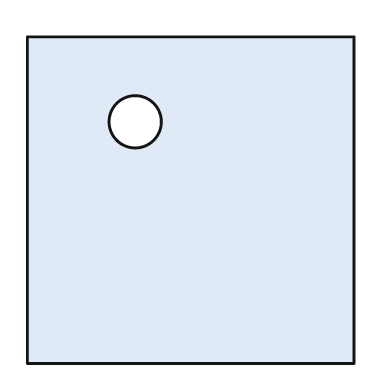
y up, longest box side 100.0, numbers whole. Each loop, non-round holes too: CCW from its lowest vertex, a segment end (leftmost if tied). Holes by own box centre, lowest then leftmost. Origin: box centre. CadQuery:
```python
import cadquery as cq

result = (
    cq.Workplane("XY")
    .moveTo(-50.0, -50.0)
    .lineTo(50.0, -50.0)
    .lineTo(50.0, 50.0)
    .lineTo(-50.0, 50.0)
    .close()
    .moveTo(-17.0, 24.0)
    .circle(8.0)
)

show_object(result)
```